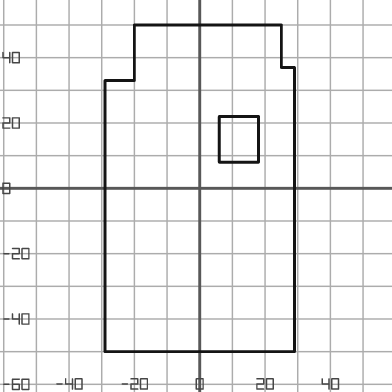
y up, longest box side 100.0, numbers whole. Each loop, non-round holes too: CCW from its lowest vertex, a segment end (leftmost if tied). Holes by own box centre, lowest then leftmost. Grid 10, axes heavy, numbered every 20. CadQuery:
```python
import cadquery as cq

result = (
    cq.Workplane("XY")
    .moveTo(-29.0, -50.0)
    .lineTo(29.0, -50.0)
    .lineTo(29.0, 37.0)
    .lineTo(25.0, 37.0)
    .lineTo(25.0, 50.0)
    .lineTo(-20.0, 50.0)
    .lineTo(-20.0, 33.0)
    .lineTo(-29.0, 33.0)
    .close()
    .moveTo(6.0, 8.0)
    .lineTo(18.0, 8.0)
    .lineTo(18.0, 22.0)
    .lineTo(6.0, 22.0)
    .close()
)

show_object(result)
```